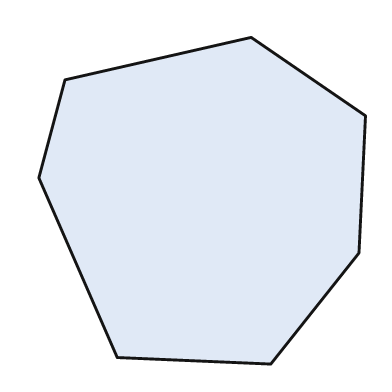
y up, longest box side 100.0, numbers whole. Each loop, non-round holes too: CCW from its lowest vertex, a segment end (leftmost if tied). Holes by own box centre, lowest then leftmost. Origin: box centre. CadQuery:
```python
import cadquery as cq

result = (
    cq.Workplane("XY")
    .moveTo(21.0, -50.0)
    .lineTo(48.0, -16.0)
    .lineTo(50.0, 26.0)
    .lineTo(15.0, 50.0)
    .lineTo(-42.0, 37.0)
    .lineTo(-50.0, 7.0)
    .lineTo(-26.0, -48.0)
    .close()
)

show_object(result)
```